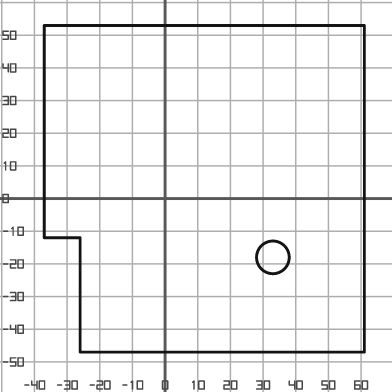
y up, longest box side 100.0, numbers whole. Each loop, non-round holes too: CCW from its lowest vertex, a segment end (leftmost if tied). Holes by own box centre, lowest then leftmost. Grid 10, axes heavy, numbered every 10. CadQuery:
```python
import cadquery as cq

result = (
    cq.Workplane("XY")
    .moveTo(-26.0, -47.0)
    .lineTo(61.0, -47.0)
    .lineTo(61.0, 53.0)
    .lineTo(-37.0, 53.0)
    .lineTo(-37.0, -12.0)
    .lineTo(-26.0, -12.0)
    .close()
    .moveTo(33.0, -18.0)
    .circle(5.0)
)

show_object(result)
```